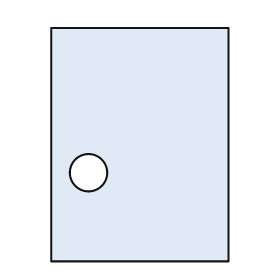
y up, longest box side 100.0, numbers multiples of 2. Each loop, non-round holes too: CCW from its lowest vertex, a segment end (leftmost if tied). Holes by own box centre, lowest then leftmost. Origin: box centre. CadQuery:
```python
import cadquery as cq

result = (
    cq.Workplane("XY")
    .moveTo(-38.0, -50.0)
    .lineTo(38.0, -50.0)
    .lineTo(38.0, 50.0)
    .lineTo(-38.0, 50.0)
    .close()
    .moveTo(-22.0, -12.0)
    .circle(8.0)
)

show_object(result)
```